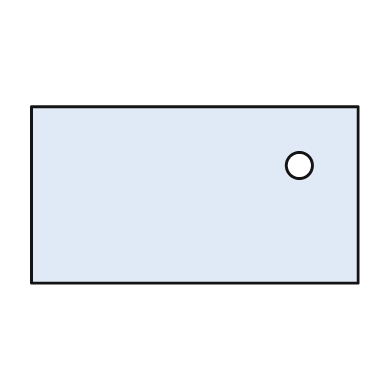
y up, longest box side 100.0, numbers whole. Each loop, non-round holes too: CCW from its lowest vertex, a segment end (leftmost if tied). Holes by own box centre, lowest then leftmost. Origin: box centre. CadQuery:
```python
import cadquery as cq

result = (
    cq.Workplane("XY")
    .moveTo(-50.0, -27.0)
    .lineTo(50.0, -27.0)
    .lineTo(50.0, 27.0)
    .lineTo(-50.0, 27.0)
    .close()
    .moveTo(32.0, 9.0)
    .circle(4.0)
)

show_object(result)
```